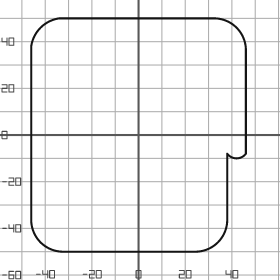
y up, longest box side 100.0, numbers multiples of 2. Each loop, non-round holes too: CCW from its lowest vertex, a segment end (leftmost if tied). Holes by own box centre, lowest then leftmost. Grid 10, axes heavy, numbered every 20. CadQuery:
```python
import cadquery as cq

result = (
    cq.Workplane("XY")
    .moveTo(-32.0, -50.0)
    .lineTo(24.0, -50.0)
    .threePointArc((34.0, -46.0), (38.0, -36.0))
    .lineTo(38.0, -8.0)
    .threePointArc((42.0, -10.0), (46.0, -8.0))
    .lineTo(46.0, 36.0)
    .threePointArc((42.0, 46.0), (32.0, 50.0))
    .lineTo(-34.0, 50.0)
    .threePointArc((-42.0, 46.0), (-46.0, 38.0))
    .lineTo(-46.0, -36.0)
    .threePointArc((-42.0, -46.0), (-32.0, -50.0))
    .close()
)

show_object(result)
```